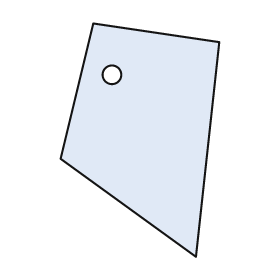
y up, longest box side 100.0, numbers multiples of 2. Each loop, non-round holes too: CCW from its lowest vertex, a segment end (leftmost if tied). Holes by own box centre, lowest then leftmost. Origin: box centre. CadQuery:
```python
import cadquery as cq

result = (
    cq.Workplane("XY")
    .moveTo(24.0, -50.0)
    .lineTo(34.0, 42.0)
    .lineTo(-20.0, 50.0)
    .lineTo(-34.0, -8.0)
    .close()
    .moveTo(-12.0, 28.0)
    .circle(4.0)
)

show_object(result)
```